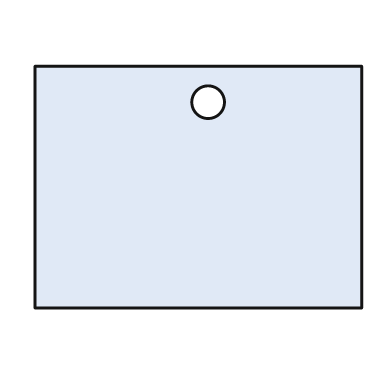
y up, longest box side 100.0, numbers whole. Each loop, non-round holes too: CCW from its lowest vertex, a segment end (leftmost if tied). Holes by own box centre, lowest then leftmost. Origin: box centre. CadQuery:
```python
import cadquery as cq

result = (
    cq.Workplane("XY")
    .moveTo(-50.0, -37.0)
    .lineTo(50.0, -37.0)
    .lineTo(50.0, 37.0)
    .lineTo(-50.0, 37.0)
    .close()
    .moveTo(3.0, 26.0)
    .circle(5.0)
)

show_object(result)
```